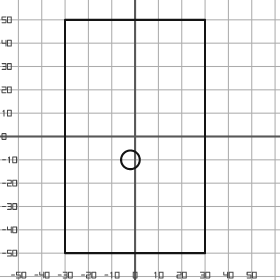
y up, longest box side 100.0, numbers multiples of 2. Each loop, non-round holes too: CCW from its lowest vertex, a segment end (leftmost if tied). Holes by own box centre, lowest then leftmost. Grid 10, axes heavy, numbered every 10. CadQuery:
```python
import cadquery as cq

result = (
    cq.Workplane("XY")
    .moveTo(-30.0, -50.0)
    .lineTo(30.0, -50.0)
    .lineTo(30.0, 50.0)
    .lineTo(-30.0, 50.0)
    .close()
    .moveTo(-2.0, -10.0)
    .circle(4.0)
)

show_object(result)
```